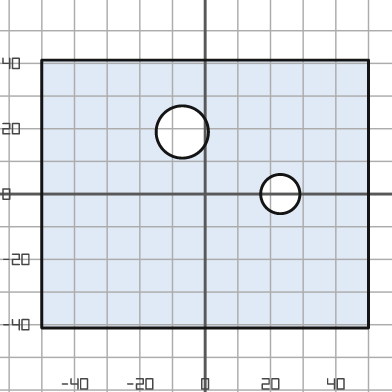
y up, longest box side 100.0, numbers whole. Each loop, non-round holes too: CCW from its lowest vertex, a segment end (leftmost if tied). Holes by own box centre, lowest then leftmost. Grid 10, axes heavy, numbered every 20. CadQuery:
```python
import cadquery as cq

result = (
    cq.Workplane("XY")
    .moveTo(-50.0, -41.0)
    .lineTo(50.0, -41.0)
    .lineTo(50.0, 41.0)
    .lineTo(-50.0, 41.0)
    .close()
    .moveTo(23.0, 0.0)
    .circle(6.0)
    .moveTo(-7.0, 19.0)
    .circle(8.0)
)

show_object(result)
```